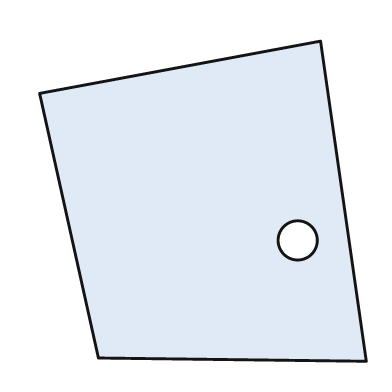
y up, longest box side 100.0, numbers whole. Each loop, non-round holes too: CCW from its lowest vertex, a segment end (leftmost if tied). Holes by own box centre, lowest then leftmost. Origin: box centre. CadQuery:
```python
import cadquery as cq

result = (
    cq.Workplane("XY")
    .moveTo(50.0, -49.0)
    .lineTo(36.0, 49.0)
    .lineTo(-50.0, 33.0)
    .lineTo(-32.0, -48.0)
    .close()
    .moveTo(29.0, -12.0)
    .circle(6.0)
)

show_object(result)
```